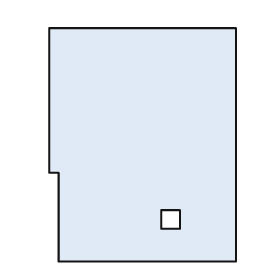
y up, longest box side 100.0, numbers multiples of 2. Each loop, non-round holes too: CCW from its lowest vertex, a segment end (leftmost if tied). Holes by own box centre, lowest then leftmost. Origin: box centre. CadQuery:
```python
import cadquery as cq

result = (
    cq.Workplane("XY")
    .moveTo(-36.0, -50.0)
    .lineTo(40.0, -50.0)
    .lineTo(40.0, 50.0)
    .lineTo(-40.0, 50.0)
    .lineTo(-40.0, -12.0)
    .lineTo(-36.0, -12.0)
    .close()
    .moveTo(8.0, -36.0)
    .lineTo(16.0, -36.0)
    .lineTo(16.0, -28.0)
    .lineTo(8.0, -28.0)
    .close()
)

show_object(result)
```